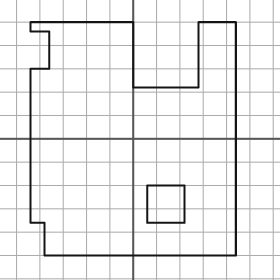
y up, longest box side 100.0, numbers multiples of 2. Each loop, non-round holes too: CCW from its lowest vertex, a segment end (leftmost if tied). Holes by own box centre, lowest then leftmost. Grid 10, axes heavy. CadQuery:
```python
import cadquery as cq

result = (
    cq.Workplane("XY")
    .moveTo(-38.0, -50.0)
    .lineTo(44.0, -50.0)
    .lineTo(44.0, 50.0)
    .lineTo(28.0, 50.0)
    .lineTo(28.0, 22.0)
    .lineTo(0.0, 22.0)
    .lineTo(0.0, 50.0)
    .lineTo(-44.0, 50.0)
    .lineTo(-44.0, 46.0)
    .lineTo(-36.0, 46.0)
    .lineTo(-36.0, 30.0)
    .lineTo(-44.0, 30.0)
    .lineTo(-44.0, -36.0)
    .lineTo(-38.0, -36.0)
    .close()
    .moveTo(6.0, -36.0)
    .lineTo(22.0, -36.0)
    .lineTo(22.0, -20.0)
    .lineTo(6.0, -20.0)
    .close()
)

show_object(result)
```